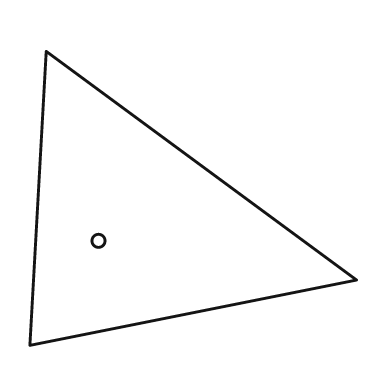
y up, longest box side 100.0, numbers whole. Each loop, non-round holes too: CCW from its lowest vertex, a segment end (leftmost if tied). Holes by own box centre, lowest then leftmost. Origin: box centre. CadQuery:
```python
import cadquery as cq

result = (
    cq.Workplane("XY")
    .moveTo(-50.0, -45.0)
    .lineTo(50.0, -25.0)
    .lineTo(-45.0, 45.0)
    .close()
    .moveTo(-29.0, -13.0)
    .circle(2.0)
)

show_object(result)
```